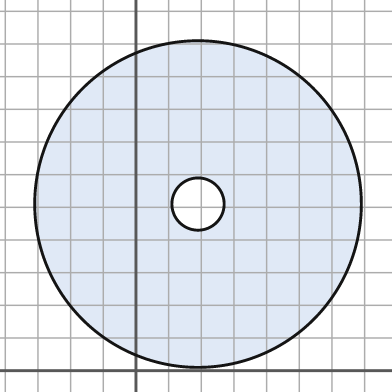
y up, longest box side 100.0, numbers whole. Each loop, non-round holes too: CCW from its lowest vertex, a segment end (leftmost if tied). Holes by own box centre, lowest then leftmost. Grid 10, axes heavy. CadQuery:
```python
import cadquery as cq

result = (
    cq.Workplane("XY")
    .moveTo(19.0, 51.0)
    .circle(50.0)
    .moveTo(19.0, 51.0)
    .circle(8.0)
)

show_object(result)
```